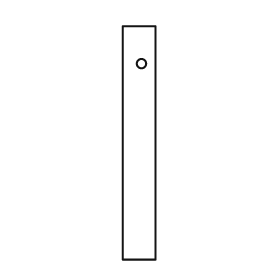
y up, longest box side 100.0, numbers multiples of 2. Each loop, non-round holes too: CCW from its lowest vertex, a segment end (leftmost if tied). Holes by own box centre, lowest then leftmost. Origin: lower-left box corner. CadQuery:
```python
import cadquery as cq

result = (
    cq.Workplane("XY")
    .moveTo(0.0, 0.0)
    .lineTo(14.0, 0.0)
    .lineTo(14.0, 100.0)
    .lineTo(0.0, 100.0)
    .close()
    .moveTo(8.0, 84.0)
    .circle(2.0)
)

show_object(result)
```